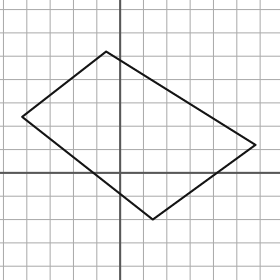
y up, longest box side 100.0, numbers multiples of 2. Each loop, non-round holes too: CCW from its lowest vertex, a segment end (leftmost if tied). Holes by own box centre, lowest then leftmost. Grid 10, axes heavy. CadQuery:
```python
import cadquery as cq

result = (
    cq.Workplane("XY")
    .moveTo(14.0, -20.0)
    .lineTo(58.0, 12.0)
    .lineTo(-6.0, 52.0)
    .lineTo(-42.0, 24.0)
    .close()
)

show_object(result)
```